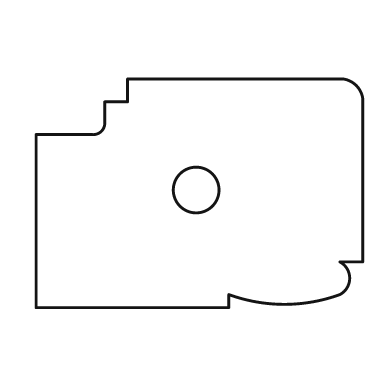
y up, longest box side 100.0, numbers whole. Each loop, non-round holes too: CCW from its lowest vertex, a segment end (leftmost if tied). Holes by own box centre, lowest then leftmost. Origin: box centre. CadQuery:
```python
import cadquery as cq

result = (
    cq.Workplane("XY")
    .moveTo(-50.0, -35.0)
    .lineTo(9.0, -35.0)
    .lineTo(9.0, -31.0)
    .threePointArc((26.0, -34.0), (43.0, -31.0))
    .threePointArc((46.0, -26.0), (43.0, -21.0))
    .lineTo(50.0, -21.0)
    .lineTo(50.0, 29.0)
    .threePointArc((48.0, 33.0), (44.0, 35.0))
    .lineTo(-22.0, 35.0)
    .lineTo(-22.0, 28.0)
    .lineTo(-29.0, 28.0)
    .lineTo(-29.0, 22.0)
    .threePointArc((-30.0, 19.0), (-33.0, 18.0))
    .lineTo(-50.0, 18.0)
    .close()
    .moveTo(-1.0, 1.0)
    .circle(7.0)
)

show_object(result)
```